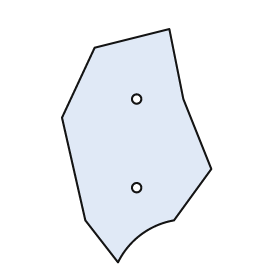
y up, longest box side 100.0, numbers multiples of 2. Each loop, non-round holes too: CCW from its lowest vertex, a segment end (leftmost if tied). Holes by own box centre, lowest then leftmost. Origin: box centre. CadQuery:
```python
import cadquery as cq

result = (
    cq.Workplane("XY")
    .moveTo(-8.0, -50.0)
    .threePointArc((2.0, -38.0), (16.0, -32.0))
    .lineTo(32.0, -10.0)
    .lineTo(20.0, 20.0)
    .lineTo(14.0, 50.0)
    .lineTo(-18.0, 42.0)
    .lineTo(-32.0, 12.0)
    .lineTo(-22.0, -32.0)
    .close()
    .moveTo(0.0, -18.0)
    .circle(2.0)
    .moveTo(0.0, 20.0)
    .circle(2.0)
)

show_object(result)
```